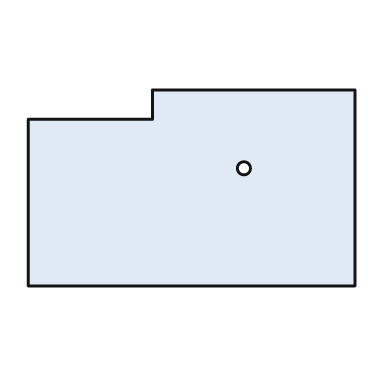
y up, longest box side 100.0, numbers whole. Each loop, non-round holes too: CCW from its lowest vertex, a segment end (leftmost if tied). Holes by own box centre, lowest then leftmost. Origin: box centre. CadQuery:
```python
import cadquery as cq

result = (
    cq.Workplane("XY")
    .moveTo(-50.0, -30.0)
    .lineTo(50.0, -30.0)
    .lineTo(50.0, 30.0)
    .lineTo(-12.0, 30.0)
    .lineTo(-12.0, 21.0)
    .lineTo(-50.0, 21.0)
    .close()
    .moveTo(16.0, 6.0)
    .circle(2.0)
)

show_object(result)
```